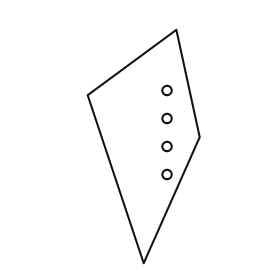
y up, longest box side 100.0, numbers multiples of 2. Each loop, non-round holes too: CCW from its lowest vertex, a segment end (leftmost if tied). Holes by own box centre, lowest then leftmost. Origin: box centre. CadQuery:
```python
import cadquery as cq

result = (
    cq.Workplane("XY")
    .moveTo(0.0, -50.0)
    .lineTo(24.0, 4.0)
    .lineTo(14.0, 50.0)
    .lineTo(-24.0, 22.0)
    .close()
    .moveTo(10.0, -12.0)
    .circle(2.0)
    .moveTo(10.0, 0.0)
    .circle(2.0)
    .moveTo(10.0, 12.0)
    .circle(2.0)
    .moveTo(10.0, 24.0)
    .circle(2.0)
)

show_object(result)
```